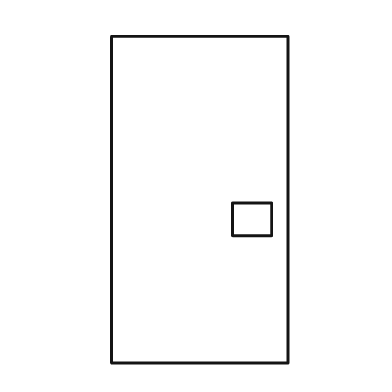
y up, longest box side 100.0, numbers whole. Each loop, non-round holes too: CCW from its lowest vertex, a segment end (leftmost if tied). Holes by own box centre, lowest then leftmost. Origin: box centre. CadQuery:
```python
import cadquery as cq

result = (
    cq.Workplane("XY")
    .moveTo(-27.0, -50.0)
    .lineTo(27.0, -50.0)
    .lineTo(27.0, 50.0)
    .lineTo(-27.0, 50.0)
    .close()
    .moveTo(10.0, -11.0)
    .lineTo(22.0, -11.0)
    .lineTo(22.0, -1.0)
    .lineTo(10.0, -1.0)
    .close()
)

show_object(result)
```